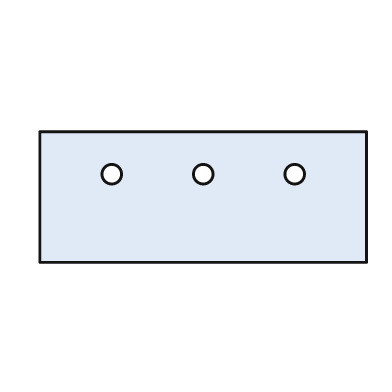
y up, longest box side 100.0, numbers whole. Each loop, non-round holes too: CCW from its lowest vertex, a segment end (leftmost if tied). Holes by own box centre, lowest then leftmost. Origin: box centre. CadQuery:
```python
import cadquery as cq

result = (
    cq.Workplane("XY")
    .moveTo(-50.0, -20.0)
    .lineTo(50.0, -20.0)
    .lineTo(50.0, 20.0)
    .lineTo(-50.0, 20.0)
    .close()
    .moveTo(-28.0, 7.0)
    .circle(3.0)
    .moveTo(0.0, 7.0)
    .circle(3.0)
    .moveTo(28.0, 7.0)
    .circle(3.0)
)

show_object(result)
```